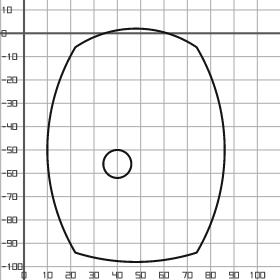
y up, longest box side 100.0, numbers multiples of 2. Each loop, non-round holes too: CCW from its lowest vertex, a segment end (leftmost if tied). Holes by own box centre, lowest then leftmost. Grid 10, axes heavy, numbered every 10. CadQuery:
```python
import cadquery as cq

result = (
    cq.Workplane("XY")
    .moveTo(22.0, -94.0)
    .threePointArc((48.0, -98.0), (74.0, -94.0))
    .threePointArc((86.0, -50.0), (74.0, -6.0))
    .threePointArc((48.0, 2.0), (22.0, -6.0))
    .threePointArc((10.0, -50.0), (22.0, -94.0))
    .close()
    .moveTo(40.0, -56.0)
    .circle(6.0)
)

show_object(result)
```